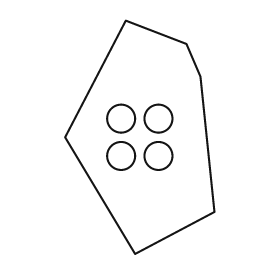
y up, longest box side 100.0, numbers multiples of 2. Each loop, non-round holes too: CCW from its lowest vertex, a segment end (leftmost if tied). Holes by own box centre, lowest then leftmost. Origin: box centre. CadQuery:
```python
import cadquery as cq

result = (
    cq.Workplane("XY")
    .moveTo(-2.0, -50.0)
    .lineTo(32.0, -32.0)
    .lineTo(26.0, 26.0)
    .lineTo(20.0, 40.0)
    .lineTo(-6.0, 50.0)
    .lineTo(-32.0, 0.0)
    .close()
    .moveTo(-8.0, -8.0)
    .circle(6.0)
    .moveTo(8.0, -8.0)
    .circle(6.0)
    .moveTo(-8.0, 8.0)
    .circle(6.0)
    .moveTo(8.0, 8.0)
    .circle(6.0)
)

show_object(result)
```